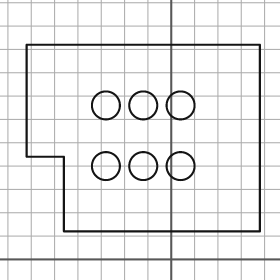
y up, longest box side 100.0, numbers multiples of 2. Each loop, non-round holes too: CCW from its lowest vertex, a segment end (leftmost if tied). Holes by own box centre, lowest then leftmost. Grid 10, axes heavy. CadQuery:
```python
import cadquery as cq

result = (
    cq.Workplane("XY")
    .moveTo(-46.0, 12.0)
    .lineTo(38.0, 12.0)
    .lineTo(38.0, 92.0)
    .lineTo(-62.0, 92.0)
    .lineTo(-62.0, 44.0)
    .lineTo(-46.0, 44.0)
    .close()
    .moveTo(-28.0, 40.0)
    .circle(6.0)
    .moveTo(-12.0, 40.0)
    .circle(6.0)
    .moveTo(4.0, 40.0)
    .circle(6.0)
    .moveTo(-28.0, 66.0)
    .circle(6.0)
    .moveTo(-12.0, 66.0)
    .circle(6.0)
    .moveTo(4.0, 66.0)
    .circle(6.0)
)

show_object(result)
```